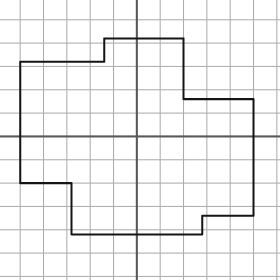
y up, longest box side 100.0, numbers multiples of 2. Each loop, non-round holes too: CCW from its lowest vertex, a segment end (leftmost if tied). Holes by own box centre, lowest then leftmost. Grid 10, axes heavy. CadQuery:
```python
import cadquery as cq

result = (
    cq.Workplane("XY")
    .moveTo(-28.0, -42.0)
    .lineTo(28.0, -42.0)
    .lineTo(28.0, -34.0)
    .lineTo(50.0, -34.0)
    .lineTo(50.0, 16.0)
    .lineTo(20.0, 16.0)
    .lineTo(20.0, 42.0)
    .lineTo(-14.0, 42.0)
    .lineTo(-14.0, 32.0)
    .lineTo(-50.0, 32.0)
    .lineTo(-50.0, -20.0)
    .lineTo(-28.0, -20.0)
    .close()
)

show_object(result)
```